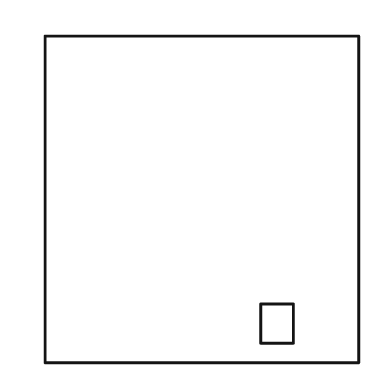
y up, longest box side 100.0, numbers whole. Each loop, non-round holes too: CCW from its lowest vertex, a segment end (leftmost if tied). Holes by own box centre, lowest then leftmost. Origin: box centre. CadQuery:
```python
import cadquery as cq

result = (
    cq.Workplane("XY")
    .moveTo(-48.0, -50.0)
    .lineTo(48.0, -50.0)
    .lineTo(48.0, 50.0)
    .lineTo(-48.0, 50.0)
    .close()
    .moveTo(18.0, -44.0)
    .lineTo(28.0, -44.0)
    .lineTo(28.0, -32.0)
    .lineTo(18.0, -32.0)
    .close()
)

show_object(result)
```